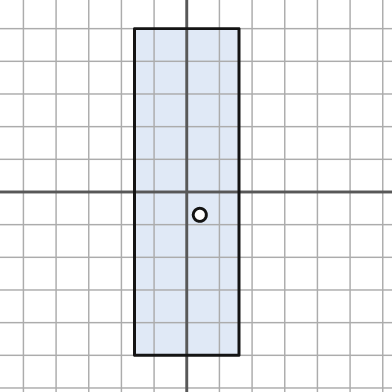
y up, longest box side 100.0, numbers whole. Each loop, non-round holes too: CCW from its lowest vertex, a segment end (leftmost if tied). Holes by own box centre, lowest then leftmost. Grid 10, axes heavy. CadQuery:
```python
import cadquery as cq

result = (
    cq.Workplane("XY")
    .moveTo(-16.0, -50.0)
    .lineTo(16.0, -50.0)
    .lineTo(16.0, 50.0)
    .lineTo(-16.0, 50.0)
    .close()
    .moveTo(4.0, -7.0)
    .circle(2.0)
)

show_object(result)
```